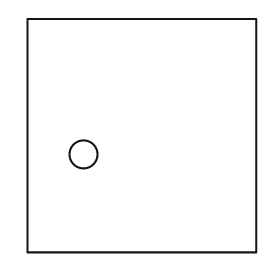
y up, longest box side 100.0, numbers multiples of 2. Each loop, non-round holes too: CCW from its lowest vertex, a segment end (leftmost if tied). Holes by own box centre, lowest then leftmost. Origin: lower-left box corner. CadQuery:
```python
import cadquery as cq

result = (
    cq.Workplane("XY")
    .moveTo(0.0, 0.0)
    .lineTo(98.0, 0.0)
    .lineTo(98.0, 100.0)
    .lineTo(0.0, 100.0)
    .close()
    .moveTo(24.0, 42.0)
    .circle(6.0)
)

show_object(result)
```